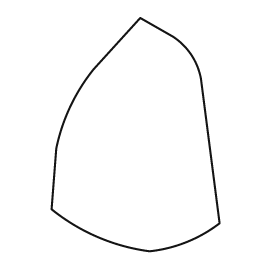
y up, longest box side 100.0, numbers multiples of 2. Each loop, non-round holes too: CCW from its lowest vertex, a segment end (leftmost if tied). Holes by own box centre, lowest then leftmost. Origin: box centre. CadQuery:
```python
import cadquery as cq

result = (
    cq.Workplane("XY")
    .moveTo(6.0, -50.0)
    .threePointArc((22.0, -46.0), (36.0, -38.0))
    .lineTo(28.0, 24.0)
    .threePointArc((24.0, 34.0), (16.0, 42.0))
    .lineTo(2.0, 50.0)
    .lineTo(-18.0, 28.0)
    .threePointArc((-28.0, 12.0), (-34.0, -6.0))
    .lineTo(-36.0, -32.0)
    .threePointArc((-16.0, -44.0), (6.0, -50.0))
    .close()
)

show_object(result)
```